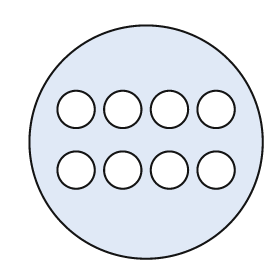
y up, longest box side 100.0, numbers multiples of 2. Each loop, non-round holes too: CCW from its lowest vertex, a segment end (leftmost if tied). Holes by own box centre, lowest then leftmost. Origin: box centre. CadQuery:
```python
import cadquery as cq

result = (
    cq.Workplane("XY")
    .moveTo(0.0, 0.0)
    .circle(50.0)
    .moveTo(-30.0, -12.0)
    .circle(8.0)
    .moveTo(-10.0, -12.0)
    .circle(8.0)
    .moveTo(10.0, -12.0)
    .circle(8.0)
    .moveTo(30.0, -12.0)
    .circle(8.0)
    .moveTo(-30.0, 14.0)
    .circle(8.0)
    .moveTo(-10.0, 14.0)
    .circle(8.0)
    .moveTo(10.0, 14.0)
    .circle(8.0)
    .moveTo(30.0, 14.0)
    .circle(8.0)
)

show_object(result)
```